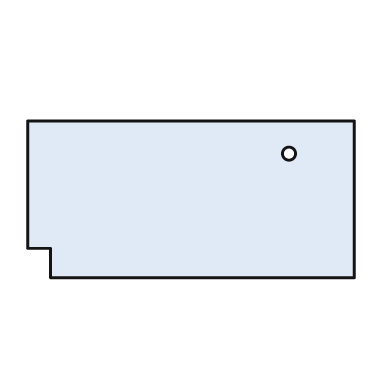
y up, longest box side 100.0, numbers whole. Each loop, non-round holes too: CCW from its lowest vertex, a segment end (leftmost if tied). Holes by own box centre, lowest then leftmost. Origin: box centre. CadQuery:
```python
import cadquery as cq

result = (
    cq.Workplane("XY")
    .moveTo(-43.0, -24.0)
    .lineTo(50.0, -24.0)
    .lineTo(50.0, 24.0)
    .lineTo(-50.0, 24.0)
    .lineTo(-50.0, -15.0)
    .lineTo(-43.0, -15.0)
    .close()
    .moveTo(30.0, 14.0)
    .circle(2.0)
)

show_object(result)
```